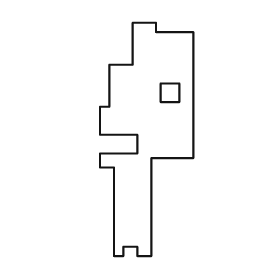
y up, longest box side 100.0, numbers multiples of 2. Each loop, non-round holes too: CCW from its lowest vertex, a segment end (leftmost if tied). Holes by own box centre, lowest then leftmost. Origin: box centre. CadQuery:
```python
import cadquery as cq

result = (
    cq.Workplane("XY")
    .moveTo(-14.0, -50.0)
    .lineTo(-10.0, -50.0)
    .lineTo(-10.0, -46.0)
    .lineTo(-4.0, -46.0)
    .lineTo(-4.0, -50.0)
    .lineTo(2.0, -50.0)
    .lineTo(2.0, -8.0)
    .lineTo(20.0, -8.0)
    .lineTo(20.0, 46.0)
    .lineTo(4.0, 46.0)
    .lineTo(4.0, 50.0)
    .lineTo(-6.0, 50.0)
    .lineTo(-6.0, 32.0)
    .lineTo(-16.0, 32.0)
    .lineTo(-16.0, 14.0)
    .lineTo(-20.0, 14.0)
    .lineTo(-20.0, 2.0)
    .lineTo(-4.0, 2.0)
    .lineTo(-4.0, -6.0)
    .lineTo(-20.0, -6.0)
    .lineTo(-20.0, -12.0)
    .lineTo(-14.0, -12.0)
    .close()
    .moveTo(6.0, 16.0)
    .lineTo(14.0, 16.0)
    .lineTo(14.0, 24.0)
    .lineTo(6.0, 24.0)
    .close()
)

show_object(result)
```